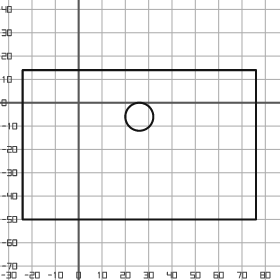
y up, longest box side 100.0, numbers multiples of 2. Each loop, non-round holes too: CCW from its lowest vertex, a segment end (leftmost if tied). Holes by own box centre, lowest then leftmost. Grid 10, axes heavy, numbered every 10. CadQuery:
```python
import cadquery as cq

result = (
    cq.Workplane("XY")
    .moveTo(-24.0, -50.0)
    .lineTo(76.0, -50.0)
    .lineTo(76.0, 14.0)
    .lineTo(-24.0, 14.0)
    .close()
    .moveTo(26.0, -6.0)
    .circle(6.0)
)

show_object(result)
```